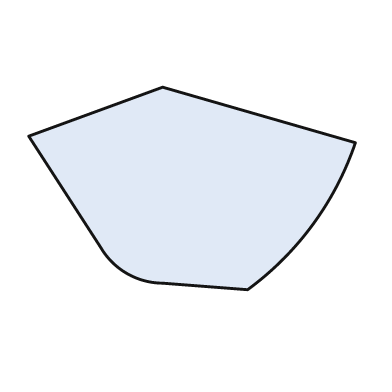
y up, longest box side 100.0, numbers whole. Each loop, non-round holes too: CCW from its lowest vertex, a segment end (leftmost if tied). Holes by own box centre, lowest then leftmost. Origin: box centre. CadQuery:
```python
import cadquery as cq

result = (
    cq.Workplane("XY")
    .moveTo(17.0, -31.0)
    .threePointArc((37.0, -11.0), (50.0, 14.0))
    .lineTo(-9.0, 31.0)
    .lineTo(-50.0, 16.0)
    .lineTo(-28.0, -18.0)
    .threePointArc((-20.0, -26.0), (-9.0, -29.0))
    .close()
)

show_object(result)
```